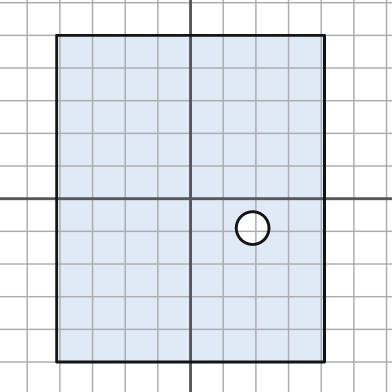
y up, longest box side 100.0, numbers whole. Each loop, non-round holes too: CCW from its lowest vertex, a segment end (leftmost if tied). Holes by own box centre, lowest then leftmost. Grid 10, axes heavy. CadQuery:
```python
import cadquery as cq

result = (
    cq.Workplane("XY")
    .moveTo(-41.0, -50.0)
    .lineTo(41.0, -50.0)
    .lineTo(41.0, 50.0)
    .lineTo(-41.0, 50.0)
    .close()
    .moveTo(19.0, -9.0)
    .circle(5.0)
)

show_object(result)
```